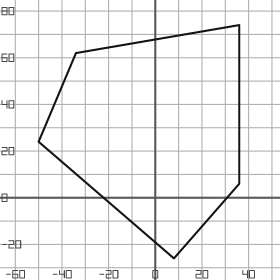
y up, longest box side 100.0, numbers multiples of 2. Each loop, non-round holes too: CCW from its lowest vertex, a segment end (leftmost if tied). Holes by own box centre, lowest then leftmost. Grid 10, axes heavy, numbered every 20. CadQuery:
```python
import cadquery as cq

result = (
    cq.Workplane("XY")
    .moveTo(8.0, -26.0)
    .lineTo(36.0, 6.0)
    .lineTo(36.0, 74.0)
    .lineTo(-34.0, 62.0)
    .lineTo(-50.0, 24.0)
    .close()
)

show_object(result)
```